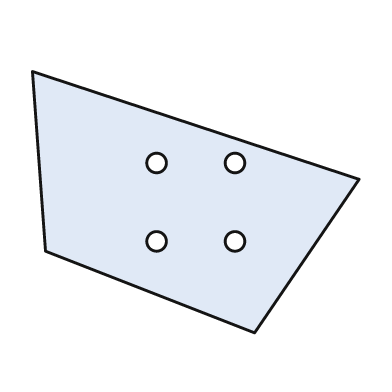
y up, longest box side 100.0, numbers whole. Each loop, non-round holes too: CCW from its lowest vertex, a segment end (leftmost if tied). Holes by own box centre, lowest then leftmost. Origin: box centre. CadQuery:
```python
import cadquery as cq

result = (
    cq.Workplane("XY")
    .moveTo(18.0, -40.0)
    .lineTo(50.0, 7.0)
    .lineTo(-50.0, 40.0)
    .lineTo(-46.0, -15.0)
    .close()
    .moveTo(-12.0, -12.0)
    .circle(3.0)
    .moveTo(12.0, -12.0)
    .circle(3.0)
    .moveTo(-12.0, 12.0)
    .circle(3.0)
    .moveTo(12.0, 12.0)
    .circle(3.0)
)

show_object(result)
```